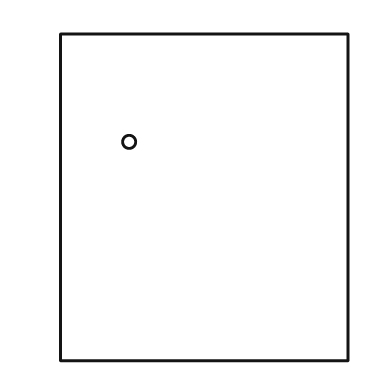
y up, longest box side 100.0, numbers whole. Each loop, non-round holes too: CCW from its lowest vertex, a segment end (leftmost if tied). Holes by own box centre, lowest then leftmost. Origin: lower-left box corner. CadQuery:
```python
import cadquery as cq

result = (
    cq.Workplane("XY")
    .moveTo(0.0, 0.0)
    .lineTo(88.0, 0.0)
    .lineTo(88.0, 100.0)
    .lineTo(0.0, 100.0)
    .close()
    .moveTo(21.0, 67.0)
    .circle(2.0)
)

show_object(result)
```